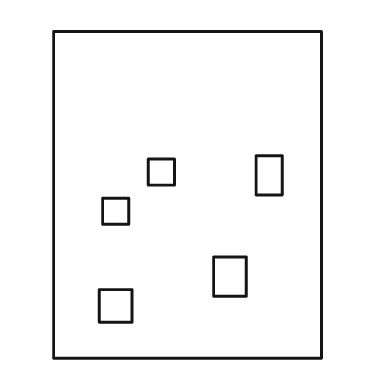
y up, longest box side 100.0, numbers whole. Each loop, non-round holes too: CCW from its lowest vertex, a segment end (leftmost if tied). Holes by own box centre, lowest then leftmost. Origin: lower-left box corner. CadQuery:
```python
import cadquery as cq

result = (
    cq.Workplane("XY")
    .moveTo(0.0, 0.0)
    .lineTo(82.0, 0.0)
    .lineTo(82.0, 100.0)
    .lineTo(0.0, 100.0)
    .close()
    .moveTo(14.0, 11.0)
    .lineTo(24.0, 11.0)
    .lineTo(24.0, 21.0)
    .lineTo(14.0, 21.0)
    .close()
    .moveTo(49.0, 19.0)
    .lineTo(59.0, 19.0)
    .lineTo(59.0, 31.0)
    .lineTo(49.0, 31.0)
    .close()
    .moveTo(15.0, 41.0)
    .lineTo(23.0, 41.0)
    .lineTo(23.0, 49.0)
    .lineTo(15.0, 49.0)
    .close()
    .moveTo(62.0, 50.0)
    .lineTo(70.0, 50.0)
    .lineTo(70.0, 62.0)
    .lineTo(62.0, 62.0)
    .close()
    .moveTo(29.0, 53.0)
    .lineTo(37.0, 53.0)
    .lineTo(37.0, 61.0)
    .lineTo(29.0, 61.0)
    .close()
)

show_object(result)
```